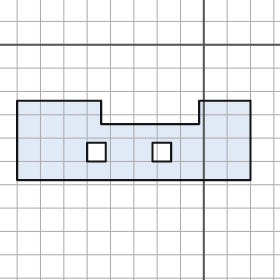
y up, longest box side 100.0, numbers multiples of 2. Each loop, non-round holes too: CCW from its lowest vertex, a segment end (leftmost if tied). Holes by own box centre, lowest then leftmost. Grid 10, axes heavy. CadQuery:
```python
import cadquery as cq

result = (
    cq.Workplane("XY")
    .moveTo(-80.0, -58.0)
    .lineTo(20.0, -58.0)
    .lineTo(20.0, -24.0)
    .lineTo(-2.0, -24.0)
    .lineTo(-2.0, -34.0)
    .lineTo(-44.0, -34.0)
    .lineTo(-44.0, -24.0)
    .lineTo(-80.0, -24.0)
    .close()
    .moveTo(-50.0, -50.0)
    .lineTo(-42.0, -50.0)
    .lineTo(-42.0, -42.0)
    .lineTo(-50.0, -42.0)
    .close()
    .moveTo(-22.0, -50.0)
    .lineTo(-14.0, -50.0)
    .lineTo(-14.0, -42.0)
    .lineTo(-22.0, -42.0)
    .close()
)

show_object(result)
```